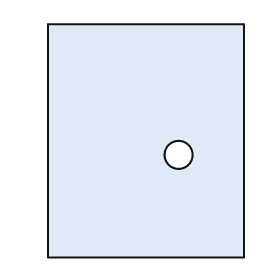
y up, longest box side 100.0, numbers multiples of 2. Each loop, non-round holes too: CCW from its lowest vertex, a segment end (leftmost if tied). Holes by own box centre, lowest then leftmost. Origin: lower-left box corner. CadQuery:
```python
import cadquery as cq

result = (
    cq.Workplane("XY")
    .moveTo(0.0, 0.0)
    .lineTo(84.0, 0.0)
    .lineTo(84.0, 100.0)
    .lineTo(0.0, 100.0)
    .close()
    .moveTo(56.0, 44.0)
    .circle(6.0)
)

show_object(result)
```